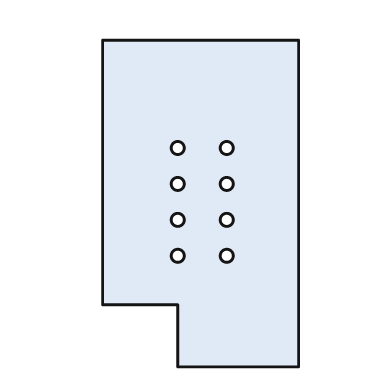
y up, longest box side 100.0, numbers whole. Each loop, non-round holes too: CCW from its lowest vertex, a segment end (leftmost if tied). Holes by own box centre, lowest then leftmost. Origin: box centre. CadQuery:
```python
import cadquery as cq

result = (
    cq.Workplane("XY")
    .moveTo(-7.0, -50.0)
    .lineTo(30.0, -50.0)
    .lineTo(30.0, 50.0)
    .lineTo(-30.0, 50.0)
    .lineTo(-30.0, -31.0)
    .lineTo(-7.0, -31.0)
    .close()
    .moveTo(-7.0, -16.0)
    .circle(2.0)
    .moveTo(8.0, -16.0)
    .circle(2.0)
    .moveTo(-7.0, -5.0)
    .circle(2.0)
    .moveTo(8.0, -5.0)
    .circle(2.0)
    .moveTo(-7.0, 6.0)
    .circle(2.0)
    .moveTo(8.0, 6.0)
    .circle(2.0)
    .moveTo(-7.0, 17.0)
    .circle(2.0)
    .moveTo(8.0, 17.0)
    .circle(2.0)
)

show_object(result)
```